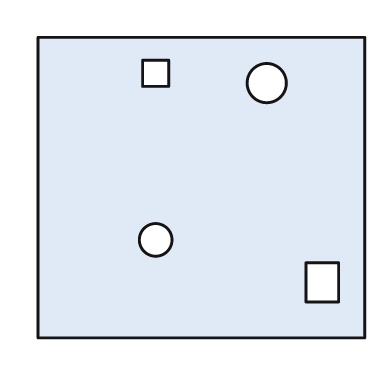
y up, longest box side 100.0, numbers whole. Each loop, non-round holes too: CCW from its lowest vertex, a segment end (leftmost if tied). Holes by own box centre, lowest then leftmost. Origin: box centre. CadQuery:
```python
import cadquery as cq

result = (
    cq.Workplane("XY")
    .moveTo(-50.0, -46.0)
    .lineTo(50.0, -46.0)
    .lineTo(50.0, 46.0)
    .lineTo(-50.0, 46.0)
    .close()
    .moveTo(32.0, -35.0)
    .lineTo(42.0, -35.0)
    .lineTo(42.0, -23.0)
    .lineTo(32.0, -23.0)
    .close()
    .moveTo(-14.0, -16.0)
    .circle(5.0)
    .moveTo(20.0, 32.0)
    .circle(6.0)
    .moveTo(-18.0, 31.0)
    .lineTo(-10.0, 31.0)
    .lineTo(-10.0, 39.0)
    .lineTo(-18.0, 39.0)
    .close()
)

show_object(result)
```